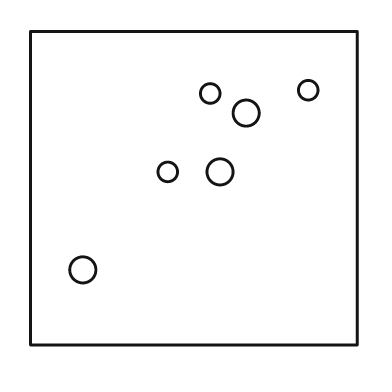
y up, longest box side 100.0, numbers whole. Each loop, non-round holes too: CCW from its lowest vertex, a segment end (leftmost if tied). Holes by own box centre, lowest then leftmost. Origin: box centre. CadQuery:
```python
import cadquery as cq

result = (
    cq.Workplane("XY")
    .moveTo(-50.0, -48.0)
    .lineTo(50.0, -48.0)
    .lineTo(50.0, 48.0)
    .lineTo(-50.0, 48.0)
    .close()
    .moveTo(-34.0, -25.0)
    .circle(4.0)
    .moveTo(-8.0, 5.0)
    .circle(3.0)
    .moveTo(8.0, 5.0)
    .circle(4.0)
    .moveTo(16.0, 23.0)
    .circle(4.0)
    .moveTo(5.0, 29.0)
    .circle(3.0)
    .moveTo(35.0, 30.0)
    .circle(3.0)
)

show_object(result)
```